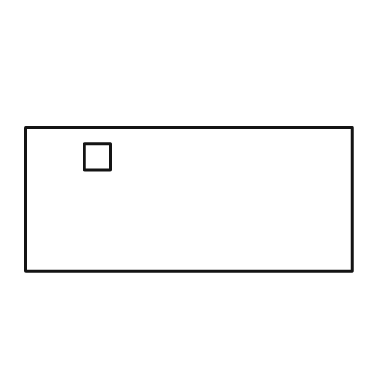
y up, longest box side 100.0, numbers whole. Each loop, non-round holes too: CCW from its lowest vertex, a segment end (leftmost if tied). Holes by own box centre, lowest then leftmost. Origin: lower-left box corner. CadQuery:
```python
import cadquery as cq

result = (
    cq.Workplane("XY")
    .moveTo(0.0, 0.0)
    .lineTo(100.0, 0.0)
    .lineTo(100.0, 44.0)
    .lineTo(0.0, 44.0)
    .close()
    .moveTo(18.0, 31.0)
    .lineTo(26.0, 31.0)
    .lineTo(26.0, 39.0)
    .lineTo(18.0, 39.0)
    .close()
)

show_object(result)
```